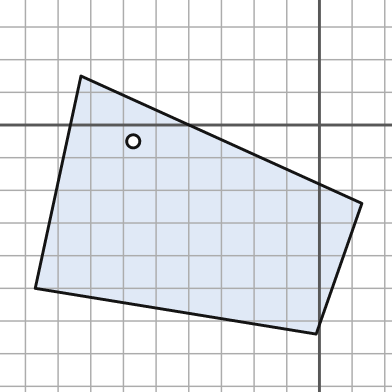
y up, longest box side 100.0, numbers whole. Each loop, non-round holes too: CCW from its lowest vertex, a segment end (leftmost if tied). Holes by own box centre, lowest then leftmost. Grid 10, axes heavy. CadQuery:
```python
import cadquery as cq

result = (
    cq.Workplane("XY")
    .moveTo(-1.0, -64.0)
    .lineTo(13.0, -24.0)
    .lineTo(-73.0, 15.0)
    .lineTo(-87.0, -50.0)
    .close()
    .moveTo(-57.0, -5.0)
    .circle(2.0)
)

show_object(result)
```